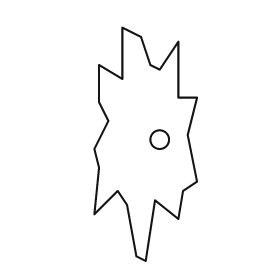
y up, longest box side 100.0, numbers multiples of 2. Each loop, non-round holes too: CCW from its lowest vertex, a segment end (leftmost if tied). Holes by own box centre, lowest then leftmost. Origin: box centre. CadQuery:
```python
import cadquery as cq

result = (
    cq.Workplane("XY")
    .moveTo(0.0, -50.0)
    .lineTo(4.0, -24.0)
    .lineTo(14.0, -32.0)
    .lineTo(16.0, -20.0)
    .lineTo(22.0, -16.0)
    .lineTo(18.0, 4.0)
    .lineTo(22.0, 20.0)
    .lineTo(14.0, 20.0)
    .lineTo(14.0, 44.0)
    .lineTo(6.0, 32.0)
    .lineTo(2.0, 34.0)
    .lineTo(-2.0, 46.0)
    .lineTo(-10.0, 50.0)
    .lineTo(-10.0, 28.0)
    .lineTo(-20.0, 34.0)
    .lineTo(-20.0, 18.0)
    .lineTo(-16.0, 10.0)
    .lineTo(-22.0, -2.0)
    .lineTo(-20.0, -10.0)
    .lineTo(-22.0, -30.0)
    .lineTo(-12.0, -20.0)
    .lineTo(-8.0, -26.0)
    .lineTo(-4.0, -48.0)
    .close()
    .moveTo(6.0, 2.0)
    .circle(4.0)
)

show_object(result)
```